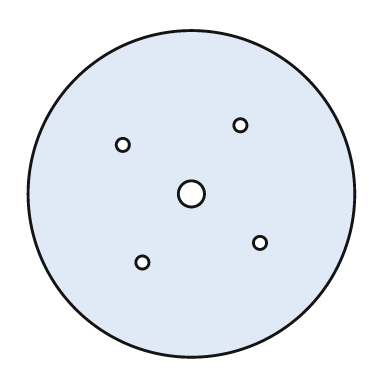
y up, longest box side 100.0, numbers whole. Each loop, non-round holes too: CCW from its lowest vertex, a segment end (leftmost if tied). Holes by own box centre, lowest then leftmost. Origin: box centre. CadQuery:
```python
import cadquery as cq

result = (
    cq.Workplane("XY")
    .moveTo(0.0, 0.0)
    .circle(50.0)
    .moveTo(-15.0, -21.0)
    .circle(2.0)
    .moveTo(21.0, -15.0)
    .circle(2.0)
    .moveTo(0.0, 0.0)
    .circle(4.0)
    .moveTo(-21.0, 15.0)
    .circle(2.0)
    .moveTo(15.0, 21.0)
    .circle(2.0)
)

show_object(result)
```